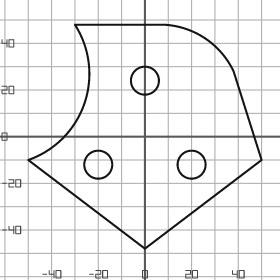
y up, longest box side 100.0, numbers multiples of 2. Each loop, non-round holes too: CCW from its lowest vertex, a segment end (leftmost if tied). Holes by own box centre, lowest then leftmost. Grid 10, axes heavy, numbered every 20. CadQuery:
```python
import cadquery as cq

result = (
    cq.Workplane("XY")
    .moveTo(0.0, -48.0)
    .lineTo(50.0, -10.0)
    .lineTo(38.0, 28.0)
    .threePointArc((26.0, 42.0), (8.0, 48.0))
    .lineTo(-30.0, 48.0)
    .threePointArc((-26.0, 14.0), (-50.0, -10.0))
    .close()
    .moveTo(-20.0, -12.0)
    .circle(6.0)
    .moveTo(20.0, -12.0)
    .circle(6.0)
    .moveTo(0.0, 24.0)
    .circle(6.0)
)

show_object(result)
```